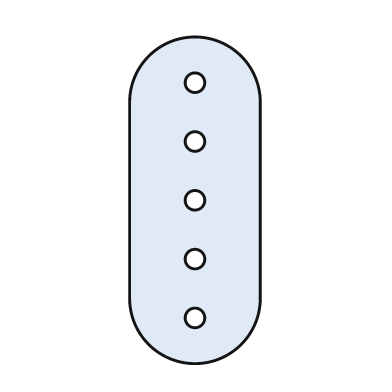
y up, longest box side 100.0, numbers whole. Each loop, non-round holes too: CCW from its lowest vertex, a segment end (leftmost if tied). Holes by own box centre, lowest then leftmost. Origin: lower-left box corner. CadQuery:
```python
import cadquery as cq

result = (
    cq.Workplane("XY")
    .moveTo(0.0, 20.0)
    .threePointArc((20.0, 0.0), (40.0, 20.0))
    .lineTo(40.0, 80.0)
    .threePointArc((20.0, 100.0), (0.0, 80.0))
    .close()
    .moveTo(20.0, 14.0)
    .circle(3.0)
    .moveTo(20.0, 32.0)
    .circle(3.0)
    .moveTo(20.0, 50.0)
    .circle(3.0)
    .moveTo(20.0, 68.0)
    .circle(3.0)
    .moveTo(20.0, 86.0)
    .circle(3.0)
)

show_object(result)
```